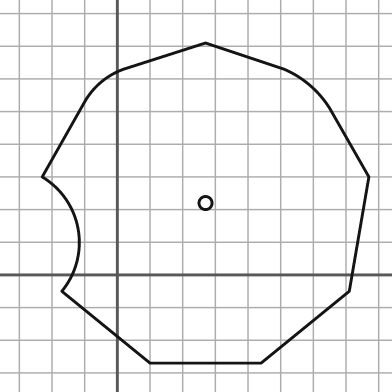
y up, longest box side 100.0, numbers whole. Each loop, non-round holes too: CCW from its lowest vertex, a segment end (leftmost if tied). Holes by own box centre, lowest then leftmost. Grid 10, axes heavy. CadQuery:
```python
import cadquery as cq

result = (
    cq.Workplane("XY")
    .moveTo(10.0, -27.0)
    .lineTo(44.0, -27.0)
    .lineTo(71.0, -5.0)
    .lineTo(77.0, 30.0)
    .lineTo(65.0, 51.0)
    .threePointArc((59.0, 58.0), (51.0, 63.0))
    .lineTo(27.0, 71.0)
    .lineTo(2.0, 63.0)
    .threePointArc((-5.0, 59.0), (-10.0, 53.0))
    .lineTo(-23.0, 30.0)
    .threePointArc((-12.0, 14.0), (-17.0, -5.0))
    .close()
    .moveTo(27.0, 22.0)
    .circle(2.0)
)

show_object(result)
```